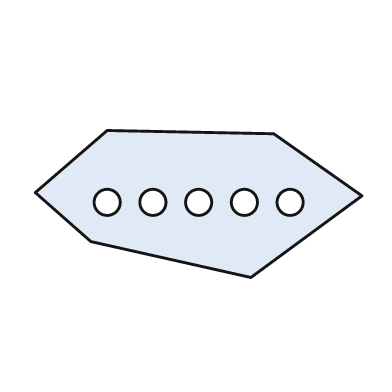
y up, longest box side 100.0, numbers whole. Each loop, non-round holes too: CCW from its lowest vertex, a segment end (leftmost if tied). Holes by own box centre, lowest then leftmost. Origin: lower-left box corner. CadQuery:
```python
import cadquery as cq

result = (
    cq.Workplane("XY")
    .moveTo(66.0, 0.0)
    .lineTo(100.0, 25.0)
    .lineTo(73.0, 44.0)
    .lineTo(22.0, 45.0)
    .lineTo(0.0, 26.0)
    .lineTo(17.0, 11.0)
    .close()
    .moveTo(22.0, 23.0)
    .circle(4.0)
    .moveTo(36.0, 23.0)
    .circle(4.0)
    .moveTo(50.0, 23.0)
    .circle(4.0)
    .moveTo(64.0, 23.0)
    .circle(4.0)
    .moveTo(78.0, 23.0)
    .circle(4.0)
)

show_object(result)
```